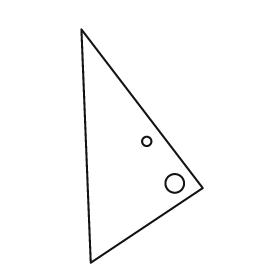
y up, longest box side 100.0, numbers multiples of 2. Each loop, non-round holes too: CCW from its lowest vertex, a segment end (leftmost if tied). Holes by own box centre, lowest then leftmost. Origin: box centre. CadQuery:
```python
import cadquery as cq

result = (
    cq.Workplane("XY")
    .moveTo(-22.0, -50.0)
    .lineTo(26.0, -18.0)
    .lineTo(-26.0, 50.0)
    .close()
    .moveTo(14.0, -16.0)
    .circle(4.0)
    .moveTo(2.0, 2.0)
    .circle(2.0)
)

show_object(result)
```